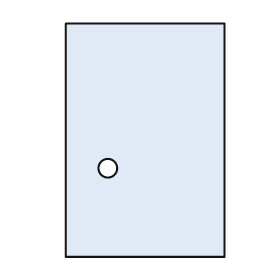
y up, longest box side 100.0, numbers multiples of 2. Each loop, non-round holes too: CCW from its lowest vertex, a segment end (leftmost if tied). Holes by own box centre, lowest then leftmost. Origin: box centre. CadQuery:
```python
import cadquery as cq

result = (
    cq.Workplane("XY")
    .moveTo(-34.0, -50.0)
    .lineTo(34.0, -50.0)
    .lineTo(34.0, 50.0)
    .lineTo(-34.0, 50.0)
    .close()
    .moveTo(-16.0, -12.0)
    .circle(4.0)
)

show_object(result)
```